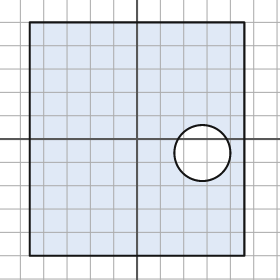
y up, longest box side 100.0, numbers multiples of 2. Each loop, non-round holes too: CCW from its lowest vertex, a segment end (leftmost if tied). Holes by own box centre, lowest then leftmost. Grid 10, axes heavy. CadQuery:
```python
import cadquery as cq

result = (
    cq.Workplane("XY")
    .moveTo(-46.0, -50.0)
    .lineTo(46.0, -50.0)
    .lineTo(46.0, 50.0)
    .lineTo(-46.0, 50.0)
    .close()
    .moveTo(28.0, -6.0)
    .circle(12.0)
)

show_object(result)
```